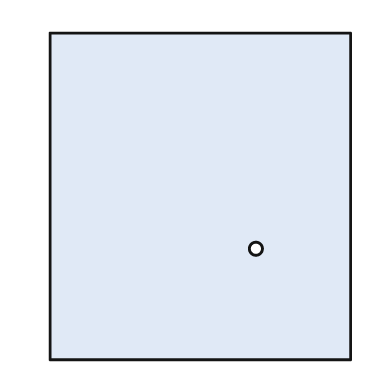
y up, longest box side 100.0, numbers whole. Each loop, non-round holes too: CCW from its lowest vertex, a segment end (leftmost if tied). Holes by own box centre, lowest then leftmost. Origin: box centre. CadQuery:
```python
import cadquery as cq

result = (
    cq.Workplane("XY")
    .moveTo(-46.0, -50.0)
    .lineTo(46.0, -50.0)
    .lineTo(46.0, 50.0)
    .lineTo(-46.0, 50.0)
    .close()
    .moveTo(17.0, -16.0)
    .circle(2.0)
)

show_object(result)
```